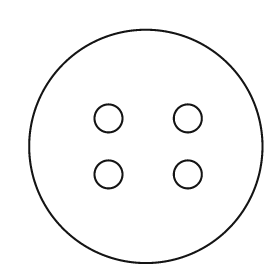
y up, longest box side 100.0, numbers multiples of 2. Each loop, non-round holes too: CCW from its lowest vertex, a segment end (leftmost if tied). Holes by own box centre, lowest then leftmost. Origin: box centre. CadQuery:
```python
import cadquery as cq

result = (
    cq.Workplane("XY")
    .moveTo(0.0, 0.0)
    .circle(50.0)
    .moveTo(-16.0, -12.0)
    .circle(6.0)
    .moveTo(18.0, -12.0)
    .circle(6.0)
    .moveTo(-16.0, 12.0)
    .circle(6.0)
    .moveTo(18.0, 12.0)
    .circle(6.0)
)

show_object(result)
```